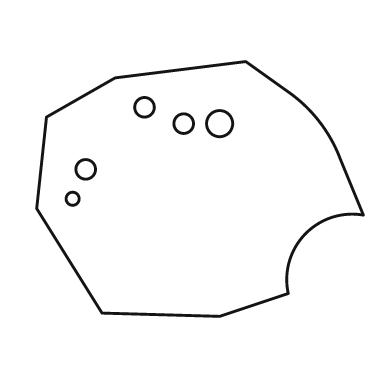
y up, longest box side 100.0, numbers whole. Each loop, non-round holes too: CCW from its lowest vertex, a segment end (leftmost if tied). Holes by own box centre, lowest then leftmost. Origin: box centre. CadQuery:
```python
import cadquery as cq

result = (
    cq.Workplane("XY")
    .moveTo(6.0, -39.0)
    .lineTo(27.0, -32.0)
    .threePointArc((32.0, -14.0), (50.0, -8.0))
    .lineTo(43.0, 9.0)
    .threePointArc((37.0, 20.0), (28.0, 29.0))
    .lineTo(14.0, 39.0)
    .lineTo(-26.0, 34.0)
    .lineTo(-47.0, 22.0)
    .lineTo(-50.0, -6.0)
    .lineTo(-30.0, -38.0)
    .close()
    .moveTo(-39.0, -3.0)
    .circle(2.0)
    .moveTo(-35.0, 6.0)
    .circle(3.0)
    .moveTo(-5.0, 20.0)
    .circle(3.0)
    .moveTo(6.0, 20.0)
    .circle(4.0)
    .moveTo(-17.0, 25.0)
    .circle(3.0)
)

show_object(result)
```